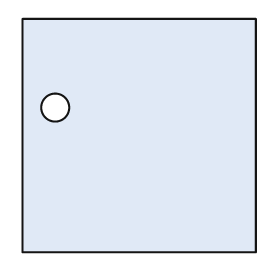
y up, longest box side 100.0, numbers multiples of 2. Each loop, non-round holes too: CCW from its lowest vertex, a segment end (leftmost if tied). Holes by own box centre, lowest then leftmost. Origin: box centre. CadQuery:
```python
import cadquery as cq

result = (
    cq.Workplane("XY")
    .moveTo(-50.0, -50.0)
    .lineTo(50.0, -50.0)
    .lineTo(50.0, 50.0)
    .lineTo(-50.0, 50.0)
    .close()
    .moveTo(-36.0, 12.0)
    .circle(6.0)
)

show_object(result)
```